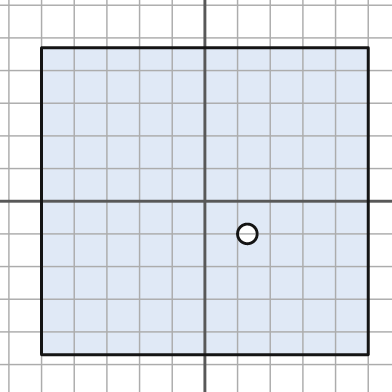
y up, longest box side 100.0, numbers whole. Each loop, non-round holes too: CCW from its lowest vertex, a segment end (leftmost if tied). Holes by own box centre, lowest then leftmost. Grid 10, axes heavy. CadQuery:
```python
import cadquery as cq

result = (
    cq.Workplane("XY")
    .moveTo(-50.0, -47.0)
    .lineTo(50.0, -47.0)
    .lineTo(50.0, 47.0)
    .lineTo(-50.0, 47.0)
    .close()
    .moveTo(13.0, -10.0)
    .circle(3.0)
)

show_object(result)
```